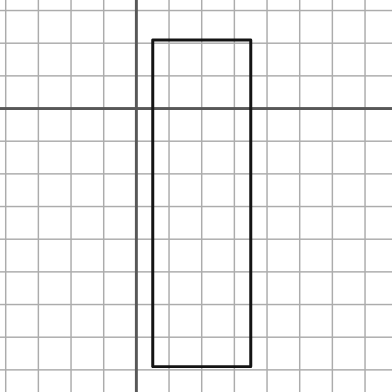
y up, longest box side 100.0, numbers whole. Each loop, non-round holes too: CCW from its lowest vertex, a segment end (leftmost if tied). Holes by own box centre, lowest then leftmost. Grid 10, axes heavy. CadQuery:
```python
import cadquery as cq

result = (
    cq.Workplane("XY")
    .moveTo(5.0, -79.0)
    .lineTo(35.0, -79.0)
    .lineTo(35.0, 21.0)
    .lineTo(5.0, 21.0)
    .close()
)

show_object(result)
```